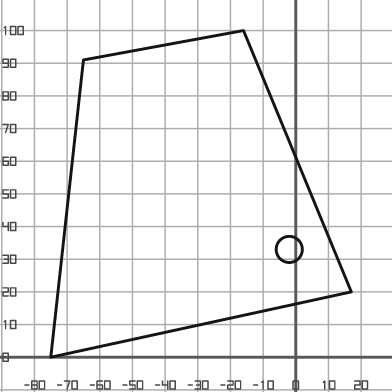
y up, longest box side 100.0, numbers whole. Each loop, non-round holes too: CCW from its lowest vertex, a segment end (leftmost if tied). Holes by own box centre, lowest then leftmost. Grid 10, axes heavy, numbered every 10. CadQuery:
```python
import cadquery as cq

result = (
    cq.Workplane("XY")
    .moveTo(-75.0, 0.0)
    .lineTo(17.0, 20.0)
    .lineTo(-16.0, 100.0)
    .lineTo(-65.0, 91.0)
    .close()
    .moveTo(-2.0, 33.0)
    .circle(4.0)
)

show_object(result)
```